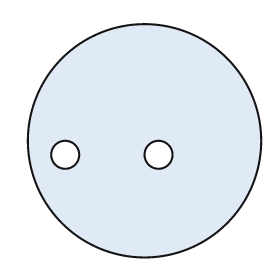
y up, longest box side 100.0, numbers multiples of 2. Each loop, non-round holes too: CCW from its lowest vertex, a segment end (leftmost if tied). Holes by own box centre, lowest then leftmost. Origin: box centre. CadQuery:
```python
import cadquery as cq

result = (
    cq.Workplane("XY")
    .moveTo(0.0, 0.0)
    .circle(50.0)
    .moveTo(-34.0, -6.0)
    .circle(6.0)
    .moveTo(6.0, -6.0)
    .circle(6.0)
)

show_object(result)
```